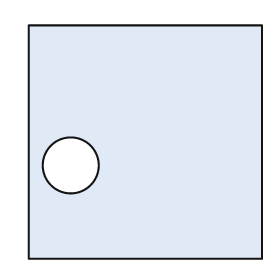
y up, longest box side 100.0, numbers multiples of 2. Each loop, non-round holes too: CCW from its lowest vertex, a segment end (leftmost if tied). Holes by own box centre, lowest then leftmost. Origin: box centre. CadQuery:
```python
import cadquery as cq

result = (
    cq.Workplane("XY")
    .moveTo(-50.0, -50.0)
    .lineTo(50.0, -50.0)
    .lineTo(50.0, 50.0)
    .lineTo(-50.0, 50.0)
    .close()
    .moveTo(-32.0, -10.0)
    .circle(12.0)
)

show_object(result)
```